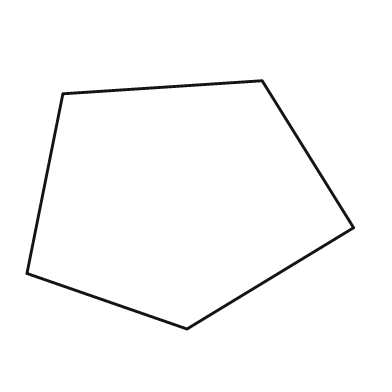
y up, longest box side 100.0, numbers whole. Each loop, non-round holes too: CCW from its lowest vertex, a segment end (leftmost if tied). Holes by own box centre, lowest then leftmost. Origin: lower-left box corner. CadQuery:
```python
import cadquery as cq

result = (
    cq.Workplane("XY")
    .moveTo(49.0, 0.0)
    .lineTo(100.0, 31.0)
    .lineTo(72.0, 76.0)
    .lineTo(11.0, 72.0)
    .lineTo(0.0, 17.0)
    .close()
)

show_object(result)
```